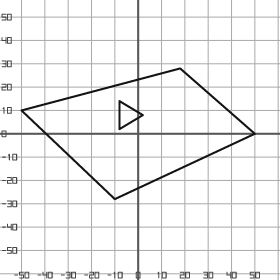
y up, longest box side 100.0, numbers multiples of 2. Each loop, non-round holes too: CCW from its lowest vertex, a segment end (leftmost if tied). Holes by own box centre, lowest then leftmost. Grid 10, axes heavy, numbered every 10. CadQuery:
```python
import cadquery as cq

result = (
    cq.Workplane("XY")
    .moveTo(-10.0, -28.0)
    .lineTo(50.0, 0.0)
    .lineTo(18.0, 28.0)
    .lineTo(-50.0, 10.0)
    .close()
    .moveTo(-8.0, 2.0)
    .lineTo(2.0, 8.0)
    .lineTo(-8.0, 14.0)
    .close()
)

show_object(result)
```